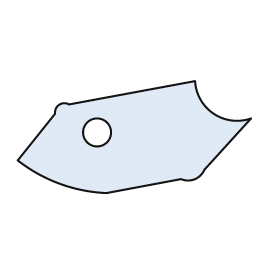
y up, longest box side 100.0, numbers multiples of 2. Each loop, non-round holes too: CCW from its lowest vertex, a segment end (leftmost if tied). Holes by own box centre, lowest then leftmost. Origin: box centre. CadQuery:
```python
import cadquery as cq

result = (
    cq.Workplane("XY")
    .moveTo(-12.0, -24.0)
    .lineTo(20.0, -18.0)
    .threePointArc((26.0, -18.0), (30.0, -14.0))
    .lineTo(50.0, 8.0)
    .threePointArc((34.0, 10.0), (26.0, 24.0))
    .lineTo(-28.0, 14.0)
    .threePointArc((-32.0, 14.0), (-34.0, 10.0))
    .lineTo(-50.0, -10.0)
    .threePointArc((-32.0, -20.0), (-12.0, -24.0))
    .close()
    .moveTo(-16.0, 2.0)
    .circle(6.0)
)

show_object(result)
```